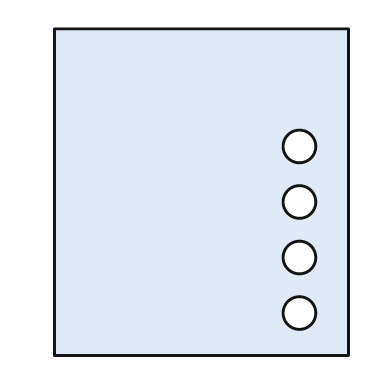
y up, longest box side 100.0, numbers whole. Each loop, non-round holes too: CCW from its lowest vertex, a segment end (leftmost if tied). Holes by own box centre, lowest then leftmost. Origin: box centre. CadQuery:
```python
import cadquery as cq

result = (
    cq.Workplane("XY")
    .moveTo(-45.0, -50.0)
    .lineTo(45.0, -50.0)
    .lineTo(45.0, 50.0)
    .lineTo(-45.0, 50.0)
    .close()
    .moveTo(30.0, -37.0)
    .circle(5.0)
    .moveTo(30.0, -20.0)
    .circle(5.0)
    .moveTo(30.0, -3.0)
    .circle(5.0)
    .moveTo(30.0, 14.0)
    .circle(5.0)
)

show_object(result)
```